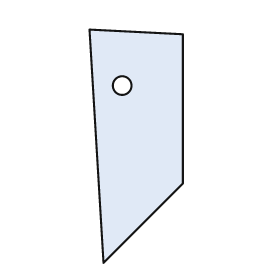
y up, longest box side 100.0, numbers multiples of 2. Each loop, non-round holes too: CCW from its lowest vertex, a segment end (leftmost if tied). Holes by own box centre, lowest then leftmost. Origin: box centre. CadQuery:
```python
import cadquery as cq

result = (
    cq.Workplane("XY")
    .moveTo(-14.0, -50.0)
    .lineTo(20.0, -16.0)
    .lineTo(20.0, 48.0)
    .lineTo(-20.0, 50.0)
    .close()
    .moveTo(-6.0, 26.0)
    .circle(4.0)
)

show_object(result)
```